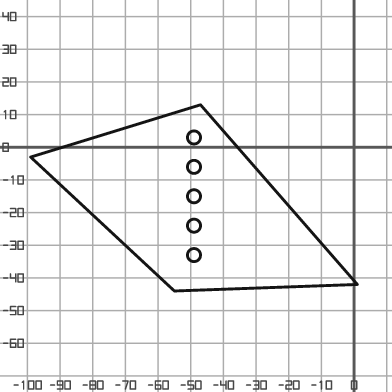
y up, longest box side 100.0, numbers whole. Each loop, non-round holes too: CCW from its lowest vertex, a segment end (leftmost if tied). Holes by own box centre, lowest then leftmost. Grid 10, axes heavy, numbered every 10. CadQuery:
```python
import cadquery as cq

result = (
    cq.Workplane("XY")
    .moveTo(-55.0, -44.0)
    .lineTo(1.0, -42.0)
    .lineTo(-47.0, 13.0)
    .lineTo(-99.0, -3.0)
    .close()
    .moveTo(-49.0, -33.0)
    .circle(2.0)
    .moveTo(-49.0, -24.0)
    .circle(2.0)
    .moveTo(-49.0, -15.0)
    .circle(2.0)
    .moveTo(-49.0, -6.0)
    .circle(2.0)
    .moveTo(-49.0, 3.0)
    .circle(2.0)
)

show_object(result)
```